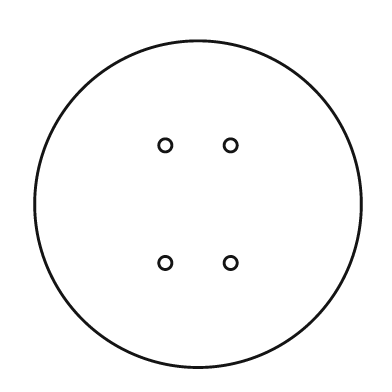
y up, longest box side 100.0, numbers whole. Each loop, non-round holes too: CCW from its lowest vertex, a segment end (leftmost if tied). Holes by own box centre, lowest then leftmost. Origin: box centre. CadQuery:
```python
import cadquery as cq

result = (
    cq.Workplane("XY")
    .moveTo(0.0, 0.0)
    .circle(50.0)
    .moveTo(-10.0, -18.0)
    .circle(2.0)
    .moveTo(10.0, -18.0)
    .circle(2.0)
    .moveTo(-10.0, 18.0)
    .circle(2.0)
    .moveTo(10.0, 18.0)
    .circle(2.0)
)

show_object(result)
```